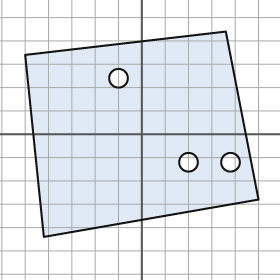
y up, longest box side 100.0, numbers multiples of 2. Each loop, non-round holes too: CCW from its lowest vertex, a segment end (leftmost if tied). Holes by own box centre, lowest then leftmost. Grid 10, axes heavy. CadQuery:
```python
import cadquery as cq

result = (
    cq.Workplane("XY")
    .moveTo(-42.0, -44.0)
    .lineTo(50.0, -28.0)
    .lineTo(36.0, 44.0)
    .lineTo(-50.0, 34.0)
    .close()
    .moveTo(20.0, -12.0)
    .circle(4.0)
    .moveTo(38.0, -12.0)
    .circle(4.0)
    .moveTo(-10.0, 24.0)
    .circle(4.0)
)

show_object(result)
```